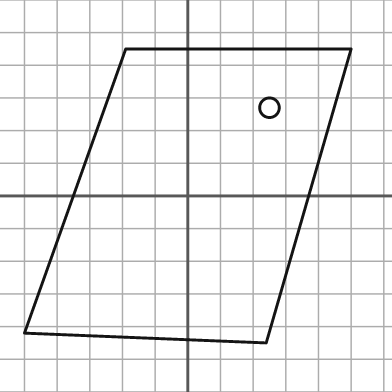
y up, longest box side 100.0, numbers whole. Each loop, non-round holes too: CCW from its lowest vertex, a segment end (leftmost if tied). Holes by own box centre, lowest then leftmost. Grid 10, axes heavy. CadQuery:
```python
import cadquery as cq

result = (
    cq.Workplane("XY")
    .moveTo(24.0, -45.0)
    .lineTo(50.0, 45.0)
    .lineTo(-19.0, 45.0)
    .lineTo(-50.0, -42.0)
    .close()
    .moveTo(25.0, 27.0)
    .circle(3.0)
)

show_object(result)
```